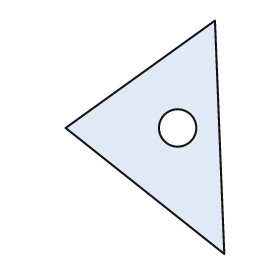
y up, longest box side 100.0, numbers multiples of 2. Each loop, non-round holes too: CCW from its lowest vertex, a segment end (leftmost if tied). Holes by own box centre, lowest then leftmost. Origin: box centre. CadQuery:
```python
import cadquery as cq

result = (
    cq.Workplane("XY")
    .moveTo(34.0, -50.0)
    .lineTo(30.0, 50.0)
    .lineTo(-34.0, 4.0)
    .close()
    .moveTo(14.0, 4.0)
    .circle(8.0)
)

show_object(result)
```